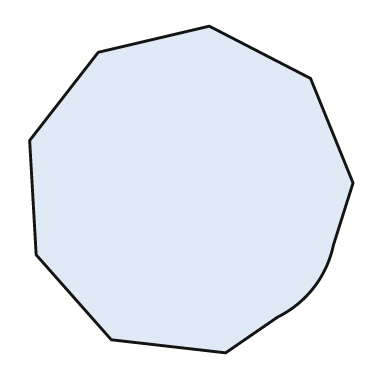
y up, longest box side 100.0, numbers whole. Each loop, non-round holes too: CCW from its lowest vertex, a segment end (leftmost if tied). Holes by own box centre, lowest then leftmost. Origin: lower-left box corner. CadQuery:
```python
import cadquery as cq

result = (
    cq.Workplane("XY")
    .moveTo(60.0, 0.0)
    .lineTo(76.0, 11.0)
    .threePointArc((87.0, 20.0), (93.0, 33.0))
    .lineTo(99.0, 52.0)
    .lineTo(86.0, 84.0)
    .lineTo(55.0, 100.0)
    .lineTo(21.0, 92.0)
    .lineTo(0.0, 65.0)
    .lineTo(2.0, 30.0)
    .lineTo(25.0, 4.0)
    .close()
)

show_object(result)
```